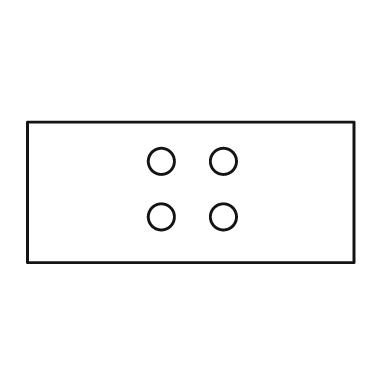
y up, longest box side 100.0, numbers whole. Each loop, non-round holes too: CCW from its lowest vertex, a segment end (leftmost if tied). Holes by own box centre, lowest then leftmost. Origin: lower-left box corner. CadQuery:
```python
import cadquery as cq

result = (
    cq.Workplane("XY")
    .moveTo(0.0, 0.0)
    .lineTo(100.0, 0.0)
    .lineTo(100.0, 43.0)
    .lineTo(0.0, 43.0)
    .close()
    .moveTo(41.0, 14.0)
    .circle(4.0)
    .moveTo(60.0, 14.0)
    .circle(4.0)
    .moveTo(41.0, 31.0)
    .circle(4.0)
    .moveTo(60.0, 31.0)
    .circle(4.0)
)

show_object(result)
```